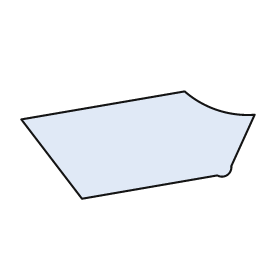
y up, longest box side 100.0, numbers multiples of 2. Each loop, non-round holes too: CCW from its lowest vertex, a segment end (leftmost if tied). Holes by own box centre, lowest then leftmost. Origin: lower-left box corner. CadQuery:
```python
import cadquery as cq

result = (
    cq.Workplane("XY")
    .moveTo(26.0, 0.0)
    .lineTo(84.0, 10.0)
    .threePointArc((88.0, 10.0), (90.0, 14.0))
    .lineTo(100.0, 36.0)
    .threePointArc((84.0, 38.0), (70.0, 46.0))
    .lineTo(0.0, 34.0)
    .close()
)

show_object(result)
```